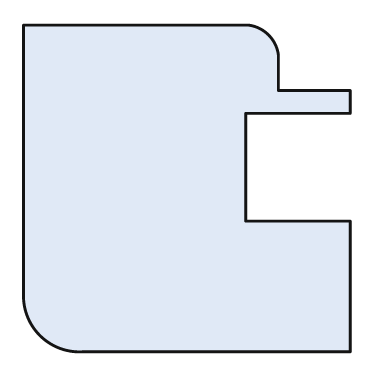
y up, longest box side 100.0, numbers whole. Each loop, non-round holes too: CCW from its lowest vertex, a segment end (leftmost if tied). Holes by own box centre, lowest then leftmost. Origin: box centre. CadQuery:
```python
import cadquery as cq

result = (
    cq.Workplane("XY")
    .moveTo(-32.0, -50.0)
    .lineTo(50.0, -50.0)
    .lineTo(50.0, -10.0)
    .lineTo(18.0, -10.0)
    .lineTo(18.0, 23.0)
    .lineTo(50.0, 23.0)
    .lineTo(50.0, 30.0)
    .lineTo(28.0, 30.0)
    .lineTo(28.0, 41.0)
    .threePointArc((25.0, 47.0), (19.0, 50.0))
    .lineTo(-50.0, 50.0)
    .lineTo(-50.0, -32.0)
    .threePointArc((-45.0, -45.0), (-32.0, -50.0))
    .close()
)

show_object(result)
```